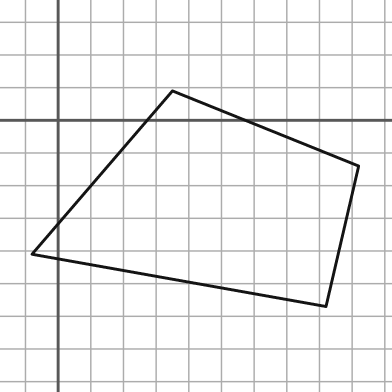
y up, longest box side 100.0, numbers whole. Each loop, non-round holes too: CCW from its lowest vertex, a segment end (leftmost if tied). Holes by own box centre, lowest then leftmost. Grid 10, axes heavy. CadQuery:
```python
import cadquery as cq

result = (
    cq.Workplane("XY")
    .moveTo(82.0, -57.0)
    .lineTo(92.0, -14.0)
    .lineTo(35.0, 9.0)
    .lineTo(-8.0, -41.0)
    .close()
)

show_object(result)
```